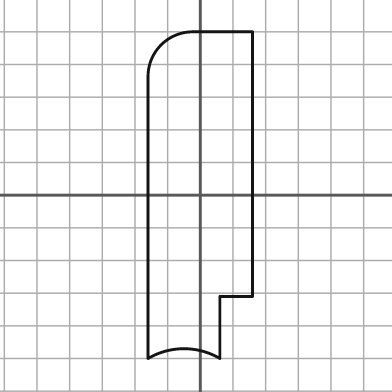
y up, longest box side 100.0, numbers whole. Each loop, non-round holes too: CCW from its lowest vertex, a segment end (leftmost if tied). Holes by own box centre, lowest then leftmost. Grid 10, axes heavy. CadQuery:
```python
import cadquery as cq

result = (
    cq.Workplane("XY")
    .moveTo(-16.0, -50.0)
    .threePointArc((-5.0, -47.0), (6.0, -50.0))
    .lineTo(6.0, -31.0)
    .lineTo(16.0, -31.0)
    .lineTo(16.0, 50.0)
    .lineTo(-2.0, 50.0)
    .threePointArc((-12.0, 46.0), (-16.0, 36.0))
    .close()
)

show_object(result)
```